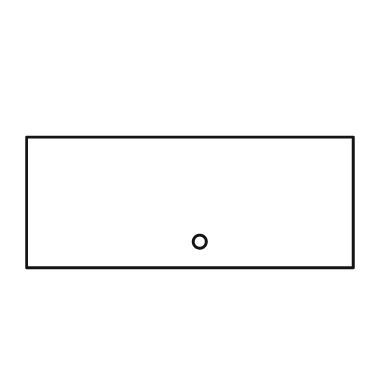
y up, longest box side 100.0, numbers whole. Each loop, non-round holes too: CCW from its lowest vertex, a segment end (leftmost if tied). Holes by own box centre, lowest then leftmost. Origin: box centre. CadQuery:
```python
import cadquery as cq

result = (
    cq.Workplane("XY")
    .moveTo(-50.0, -20.0)
    .lineTo(50.0, -20.0)
    .lineTo(50.0, 20.0)
    .lineTo(-50.0, 20.0)
    .close()
    .moveTo(3.0, -12.0)
    .circle(2.0)
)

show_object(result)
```